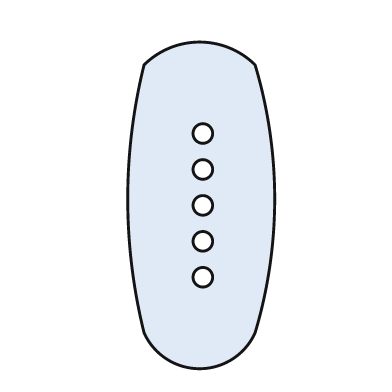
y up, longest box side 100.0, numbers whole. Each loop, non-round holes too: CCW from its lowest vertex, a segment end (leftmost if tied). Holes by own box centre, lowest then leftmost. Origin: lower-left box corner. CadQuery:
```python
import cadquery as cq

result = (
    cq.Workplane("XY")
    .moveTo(5.0, 11.0)
    .threePointArc((22.0, 0.0), (39.0, 11.0))
    .threePointArc((45.0, 52.0), (39.0, 93.0))
    .threePointArc((22.0, 100.0), (5.0, 93.0))
    .threePointArc((0.0, 52.0), (5.0, 11.0))
    .close()
    .moveTo(23.0, 28.0)
    .circle(3.0)
    .moveTo(23.0, 39.0)
    .circle(3.0)
    .moveTo(23.0, 50.0)
    .circle(3.0)
    .moveTo(23.0, 61.0)
    .circle(3.0)
    .moveTo(23.0, 72.0)
    .circle(3.0)
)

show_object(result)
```